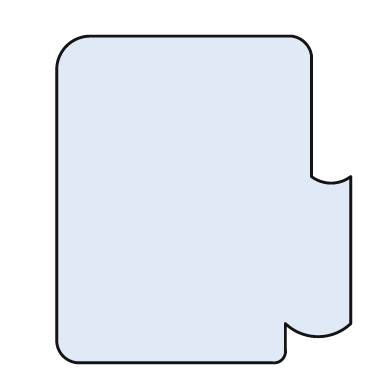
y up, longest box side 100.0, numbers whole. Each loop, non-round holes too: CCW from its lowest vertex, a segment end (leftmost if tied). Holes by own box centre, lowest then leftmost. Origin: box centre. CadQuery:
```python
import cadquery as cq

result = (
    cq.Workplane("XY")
    .moveTo(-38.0, -50.0)
    .lineTo(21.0, -50.0)
    .threePointArc((24.0, -49.0), (25.0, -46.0))
    .lineTo(25.0, -38.0)
    .threePointArc((35.0, -42.0), (45.0, -38.0))
    .lineTo(45.0, 7.0)
    .threePointArc((39.0, 5.0), (33.0, 7.0))
    .lineTo(33.0, 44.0)
    .threePointArc((31.0, 48.0), (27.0, 50.0))
    .lineTo(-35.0, 50.0)
    .threePointArc((-42.0, 47.0), (-45.0, 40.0))
    .lineTo(-45.0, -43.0)
    .threePointArc((-43.0, -48.0), (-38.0, -50.0))
    .close()
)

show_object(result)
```